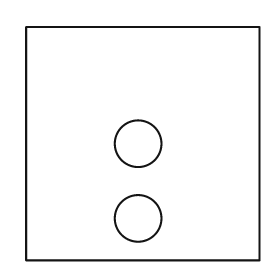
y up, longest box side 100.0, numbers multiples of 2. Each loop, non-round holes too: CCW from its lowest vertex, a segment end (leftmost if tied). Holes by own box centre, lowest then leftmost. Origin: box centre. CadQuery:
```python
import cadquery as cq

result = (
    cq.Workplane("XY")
    .moveTo(-50.0, -50.0)
    .lineTo(50.0, -50.0)
    .lineTo(50.0, 50.0)
    .lineTo(-50.0, 50.0)
    .close()
    .moveTo(-2.0, -32.0)
    .circle(10.0)
    .moveTo(-2.0, 0.0)
    .circle(10.0)
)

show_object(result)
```